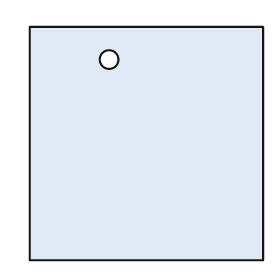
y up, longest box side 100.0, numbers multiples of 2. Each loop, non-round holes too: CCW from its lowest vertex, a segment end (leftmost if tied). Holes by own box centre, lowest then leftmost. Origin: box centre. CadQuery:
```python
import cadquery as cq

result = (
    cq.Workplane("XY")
    .moveTo(-50.0, -50.0)
    .lineTo(50.0, -50.0)
    .lineTo(50.0, 50.0)
    .lineTo(-50.0, 50.0)
    .close()
    .moveTo(-16.0, 36.0)
    .circle(4.0)
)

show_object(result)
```